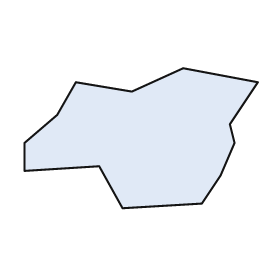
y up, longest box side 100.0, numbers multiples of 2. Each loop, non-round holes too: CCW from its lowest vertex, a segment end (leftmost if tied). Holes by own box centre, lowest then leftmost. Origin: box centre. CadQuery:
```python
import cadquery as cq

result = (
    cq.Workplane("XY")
    .moveTo(-8.0, -30.0)
    .lineTo(26.0, -28.0)
    .lineTo(34.0, -16.0)
    .lineTo(40.0, -2.0)
    .lineTo(38.0, 6.0)
    .lineTo(50.0, 24.0)
    .lineTo(18.0, 30.0)
    .lineTo(-4.0, 20.0)
    .lineTo(-28.0, 24.0)
    .lineTo(-36.0, 10.0)
    .lineTo(-50.0, -2.0)
    .lineTo(-50.0, -14.0)
    .lineTo(-18.0, -12.0)
    .close()
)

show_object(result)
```